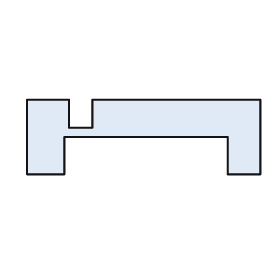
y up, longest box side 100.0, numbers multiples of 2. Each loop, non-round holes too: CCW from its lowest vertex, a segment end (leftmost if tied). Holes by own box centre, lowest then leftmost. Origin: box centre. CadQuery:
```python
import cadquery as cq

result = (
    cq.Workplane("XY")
    .moveTo(-50.0, -16.0)
    .lineTo(-34.0, -16.0)
    .lineTo(-34.0, 0.0)
    .lineTo(36.0, 0.0)
    .lineTo(36.0, -16.0)
    .lineTo(50.0, -16.0)
    .lineTo(50.0, 16.0)
    .lineTo(-22.0, 16.0)
    .lineTo(-22.0, 4.0)
    .lineTo(-32.0, 4.0)
    .lineTo(-32.0, 16.0)
    .lineTo(-50.0, 16.0)
    .close()
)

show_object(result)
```